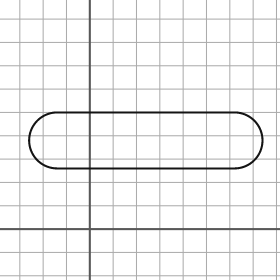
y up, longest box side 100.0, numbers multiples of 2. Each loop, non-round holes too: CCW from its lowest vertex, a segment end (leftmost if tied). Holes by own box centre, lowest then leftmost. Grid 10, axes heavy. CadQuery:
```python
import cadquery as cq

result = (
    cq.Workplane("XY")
    .moveTo(-14.0, 26.0)
    .lineTo(62.0, 26.0)
    .threePointArc((74.0, 38.0), (62.0, 50.0))
    .lineTo(-14.0, 50.0)
    .threePointArc((-26.0, 38.0), (-14.0, 26.0))
    .close()
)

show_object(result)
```